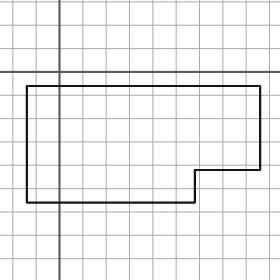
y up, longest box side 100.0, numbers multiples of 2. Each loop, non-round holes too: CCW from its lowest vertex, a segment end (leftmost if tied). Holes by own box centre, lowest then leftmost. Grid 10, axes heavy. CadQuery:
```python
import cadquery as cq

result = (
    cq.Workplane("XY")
    .moveTo(-14.0, -56.0)
    .lineTo(58.0, -56.0)
    .lineTo(58.0, -42.0)
    .lineTo(86.0, -42.0)
    .lineTo(86.0, -6.0)
    .lineTo(-14.0, -6.0)
    .close()
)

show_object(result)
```